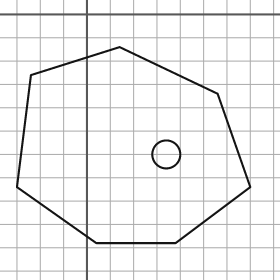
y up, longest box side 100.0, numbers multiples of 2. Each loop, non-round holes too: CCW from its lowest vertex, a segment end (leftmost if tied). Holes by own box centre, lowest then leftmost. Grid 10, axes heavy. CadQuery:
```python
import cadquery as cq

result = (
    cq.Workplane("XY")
    .moveTo(4.0, -98.0)
    .lineTo(38.0, -98.0)
    .lineTo(70.0, -74.0)
    .lineTo(56.0, -34.0)
    .lineTo(14.0, -14.0)
    .lineTo(-24.0, -26.0)
    .lineTo(-30.0, -74.0)
    .close()
    .moveTo(34.0, -60.0)
    .circle(6.0)
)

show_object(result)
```